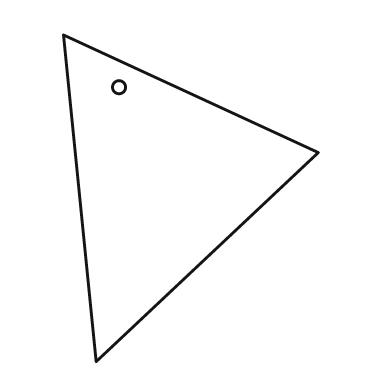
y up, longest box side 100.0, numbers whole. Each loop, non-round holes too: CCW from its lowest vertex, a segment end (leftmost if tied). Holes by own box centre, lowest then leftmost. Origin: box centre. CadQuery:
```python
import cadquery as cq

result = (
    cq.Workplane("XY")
    .moveTo(-29.0, -50.0)
    .lineTo(39.0, 14.0)
    .lineTo(-39.0, 50.0)
    .close()
    .moveTo(-22.0, 34.0)
    .circle(2.0)
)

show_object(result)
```